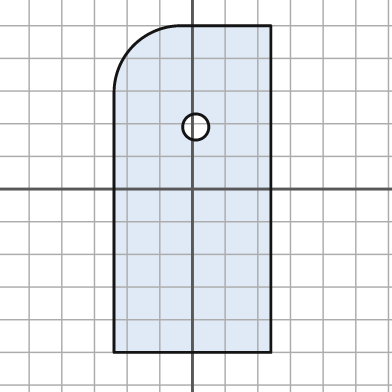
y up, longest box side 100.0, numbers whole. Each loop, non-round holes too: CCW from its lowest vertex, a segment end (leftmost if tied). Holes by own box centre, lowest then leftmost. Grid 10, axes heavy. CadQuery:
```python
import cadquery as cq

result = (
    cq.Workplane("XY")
    .moveTo(-24.0, -50.0)
    .lineTo(24.0, -50.0)
    .lineTo(24.0, 50.0)
    .lineTo(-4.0, 50.0)
    .threePointArc((-18.0, 44.0), (-24.0, 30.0))
    .close()
    .moveTo(1.0, 19.0)
    .circle(4.0)
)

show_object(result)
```